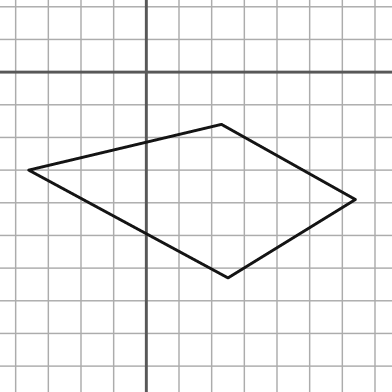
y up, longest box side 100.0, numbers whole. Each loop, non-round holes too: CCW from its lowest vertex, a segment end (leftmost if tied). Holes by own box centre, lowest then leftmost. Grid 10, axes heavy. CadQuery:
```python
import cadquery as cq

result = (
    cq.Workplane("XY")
    .moveTo(25.0, -63.0)
    .lineTo(64.0, -39.0)
    .lineTo(23.0, -16.0)
    .lineTo(-36.0, -30.0)
    .close()
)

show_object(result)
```